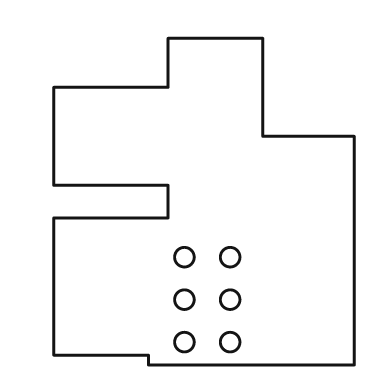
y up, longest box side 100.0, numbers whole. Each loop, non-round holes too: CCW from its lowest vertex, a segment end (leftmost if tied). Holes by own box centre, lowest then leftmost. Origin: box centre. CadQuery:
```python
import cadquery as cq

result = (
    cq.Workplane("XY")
    .moveTo(-17.0, -50.0)
    .lineTo(46.0, -50.0)
    .lineTo(46.0, 20.0)
    .lineTo(18.0, 20.0)
    .lineTo(18.0, 50.0)
    .lineTo(-11.0, 50.0)
    .lineTo(-11.0, 35.0)
    .lineTo(-46.0, 35.0)
    .lineTo(-46.0, 5.0)
    .lineTo(-11.0, 5.0)
    .lineTo(-11.0, -5.0)
    .lineTo(-46.0, -5.0)
    .lineTo(-46.0, -47.0)
    .lineTo(-17.0, -47.0)
    .close()
    .moveTo(-6.0, -43.0)
    .circle(3.0)
    .moveTo(8.0, -43.0)
    .circle(3.0)
    .moveTo(-6.0, -30.0)
    .circle(3.0)
    .moveTo(8.0, -30.0)
    .circle(3.0)
    .moveTo(-6.0, -17.0)
    .circle(3.0)
    .moveTo(8.0, -17.0)
    .circle(3.0)
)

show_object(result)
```